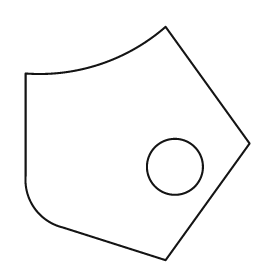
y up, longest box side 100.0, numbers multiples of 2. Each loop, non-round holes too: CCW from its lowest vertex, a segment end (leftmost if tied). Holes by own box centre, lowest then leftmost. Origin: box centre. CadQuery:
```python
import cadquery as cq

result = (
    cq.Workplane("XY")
    .moveTo(12.0, -50.0)
    .lineTo(48.0, 0.0)
    .lineTo(12.0, 50.0)
    .threePointArc((-16.0, 34.0), (-48.0, 30.0))
    .lineTo(-48.0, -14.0)
    .threePointArc((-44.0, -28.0), (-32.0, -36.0))
    .close()
    .moveTo(16.0, -10.0)
    .circle(12.0)
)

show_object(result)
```